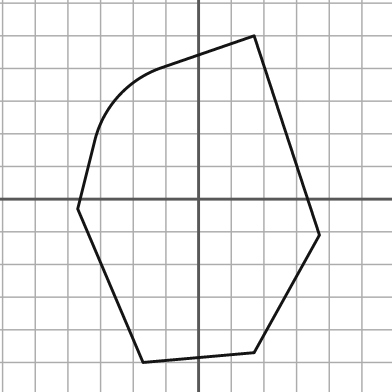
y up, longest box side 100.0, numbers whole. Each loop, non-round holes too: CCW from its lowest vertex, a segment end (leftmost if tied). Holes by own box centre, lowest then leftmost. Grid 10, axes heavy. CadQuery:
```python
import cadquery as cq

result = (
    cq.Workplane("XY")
    .moveTo(-17.0, -50.0)
    .lineTo(17.0, -47.0)
    .lineTo(37.0, -11.0)
    .lineTo(17.0, 50.0)
    .lineTo(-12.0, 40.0)
    .threePointArc((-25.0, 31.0), (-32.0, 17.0))
    .lineTo(-37.0, -3.0)
    .close()
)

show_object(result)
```